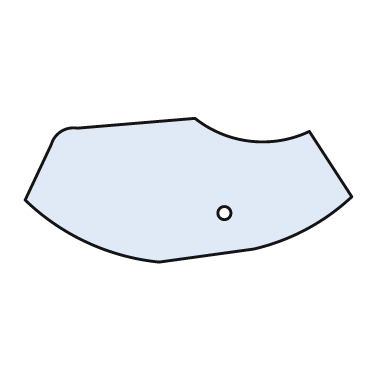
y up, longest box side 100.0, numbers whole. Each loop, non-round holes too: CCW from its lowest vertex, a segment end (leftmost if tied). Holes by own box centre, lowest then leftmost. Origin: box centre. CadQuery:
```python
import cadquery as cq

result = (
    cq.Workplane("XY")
    .moveTo(-9.0, -22.0)
    .lineTo(20.0, -18.0)
    .threePointArc((36.0, -12.0), (50.0, -2.0))
    .lineTo(37.0, 18.0)
    .threePointArc((19.0, 15.0), (2.0, 22.0))
    .lineTo(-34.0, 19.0)
    .threePointArc((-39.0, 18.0), (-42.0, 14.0))
    .lineTo(-50.0, -3.0)
    .threePointArc((-31.0, -16.0), (-9.0, -22.0))
    .close()
    .moveTo(11.0, -7.0)
    .circle(2.0)
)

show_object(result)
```